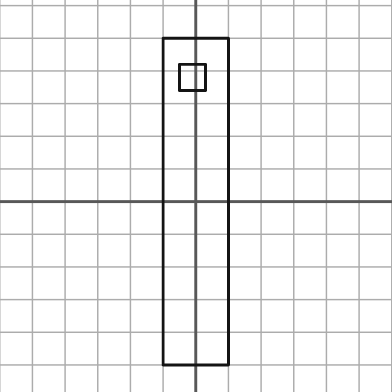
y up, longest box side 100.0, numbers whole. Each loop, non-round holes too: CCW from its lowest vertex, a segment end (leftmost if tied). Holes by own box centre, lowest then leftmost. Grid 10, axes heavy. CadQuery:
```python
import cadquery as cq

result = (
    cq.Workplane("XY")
    .moveTo(-10.0, -50.0)
    .lineTo(10.0, -50.0)
    .lineTo(10.0, 50.0)
    .lineTo(-10.0, 50.0)
    .close()
    .moveTo(-5.0, 34.0)
    .lineTo(3.0, 34.0)
    .lineTo(3.0, 42.0)
    .lineTo(-5.0, 42.0)
    .close()
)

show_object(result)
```